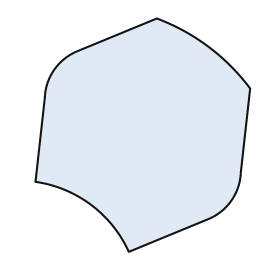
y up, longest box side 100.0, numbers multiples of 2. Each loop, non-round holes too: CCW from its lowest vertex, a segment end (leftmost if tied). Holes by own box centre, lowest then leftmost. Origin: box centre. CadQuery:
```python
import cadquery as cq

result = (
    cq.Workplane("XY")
    .moveTo(-6.0, -50.0)
    .lineTo(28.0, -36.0)
    .threePointArc((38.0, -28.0), (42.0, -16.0))
    .lineTo(46.0, 20.0)
    .threePointArc((28.0, 38.0), (6.0, 50.0))
    .lineTo(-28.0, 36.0)
    .threePointArc((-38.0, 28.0), (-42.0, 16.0))
    .lineTo(-46.0, -20.0)
    .threePointArc((-22.0, -30.0), (-6.0, -50.0))
    .close()
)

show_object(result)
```